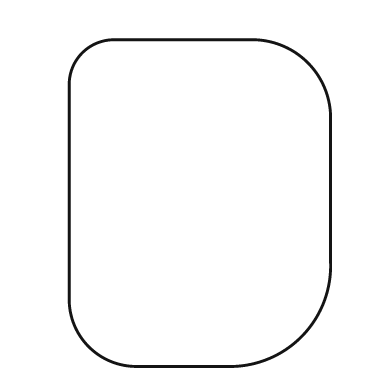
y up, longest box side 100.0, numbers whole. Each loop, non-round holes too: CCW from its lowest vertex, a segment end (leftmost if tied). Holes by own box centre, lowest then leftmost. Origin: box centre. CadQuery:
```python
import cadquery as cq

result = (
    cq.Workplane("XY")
    .moveTo(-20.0, -50.0)
    .lineTo(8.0, -50.0)
    .threePointArc((31.0, -41.0), (40.0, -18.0))
    .lineTo(40.0, 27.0)
    .threePointArc((33.0, 43.0), (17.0, 50.0))
    .lineTo(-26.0, 50.0)
    .threePointArc((-36.0, 46.0), (-40.0, 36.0))
    .lineTo(-40.0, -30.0)
    .threePointArc((-34.0, -44.0), (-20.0, -50.0))
    .close()
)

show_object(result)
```